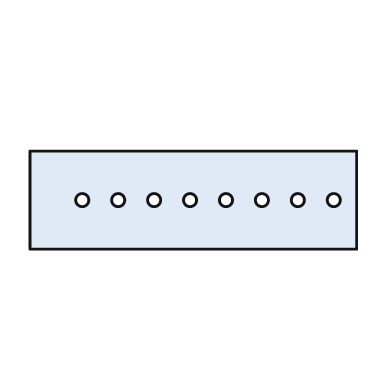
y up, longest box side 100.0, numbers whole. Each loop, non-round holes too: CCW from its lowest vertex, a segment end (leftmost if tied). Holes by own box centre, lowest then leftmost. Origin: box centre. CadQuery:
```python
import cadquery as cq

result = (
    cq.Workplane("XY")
    .moveTo(-50.0, -15.0)
    .lineTo(50.0, -15.0)
    .lineTo(50.0, 15.0)
    .lineTo(-50.0, 15.0)
    .close()
    .moveTo(-34.0, 0.0)
    .circle(2.0)
    .moveTo(-23.0, 0.0)
    .circle(2.0)
    .moveTo(-12.0, 0.0)
    .circle(2.0)
    .moveTo(-1.0, 0.0)
    .circle(2.0)
    .moveTo(10.0, 0.0)
    .circle(2.0)
    .moveTo(21.0, 0.0)
    .circle(2.0)
    .moveTo(32.0, 0.0)
    .circle(2.0)
    .moveTo(43.0, 0.0)
    .circle(2.0)
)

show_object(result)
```